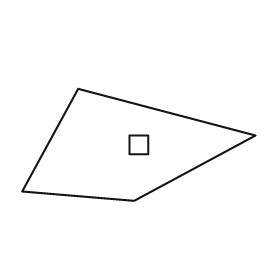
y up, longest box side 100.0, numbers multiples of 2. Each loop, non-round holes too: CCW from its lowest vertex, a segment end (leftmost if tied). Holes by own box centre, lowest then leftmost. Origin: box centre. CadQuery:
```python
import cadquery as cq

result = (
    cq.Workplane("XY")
    .moveTo(-2.0, -24.0)
    .lineTo(50.0, 4.0)
    .lineTo(-26.0, 24.0)
    .lineTo(-50.0, -20.0)
    .close()
    .moveTo(-4.0, -4.0)
    .lineTo(4.0, -4.0)
    .lineTo(4.0, 4.0)
    .lineTo(-4.0, 4.0)
    .close()
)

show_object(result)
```